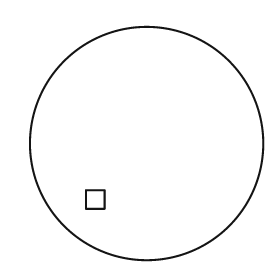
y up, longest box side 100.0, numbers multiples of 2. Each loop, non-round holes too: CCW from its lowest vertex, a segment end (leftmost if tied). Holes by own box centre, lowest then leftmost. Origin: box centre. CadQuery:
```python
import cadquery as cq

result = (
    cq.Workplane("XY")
    .moveTo(0.0, 0.0)
    .circle(50.0)
    .moveTo(-26.0, -28.0)
    .lineTo(-18.0, -28.0)
    .lineTo(-18.0, -20.0)
    .lineTo(-26.0, -20.0)
    .close()
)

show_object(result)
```